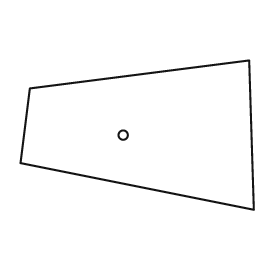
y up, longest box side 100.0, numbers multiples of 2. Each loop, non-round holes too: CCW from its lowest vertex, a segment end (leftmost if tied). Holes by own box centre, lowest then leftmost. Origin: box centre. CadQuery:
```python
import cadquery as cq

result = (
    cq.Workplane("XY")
    .moveTo(50.0, -32.0)
    .lineTo(48.0, 32.0)
    .lineTo(-46.0, 20.0)
    .lineTo(-50.0, -12.0)
    .close()
    .moveTo(-6.0, 0.0)
    .circle(2.0)
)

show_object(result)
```